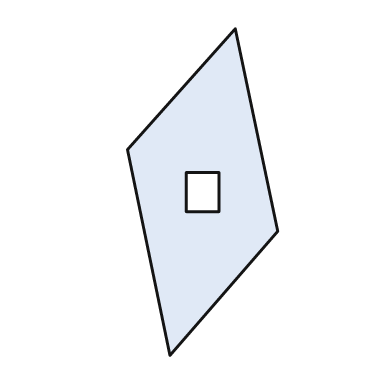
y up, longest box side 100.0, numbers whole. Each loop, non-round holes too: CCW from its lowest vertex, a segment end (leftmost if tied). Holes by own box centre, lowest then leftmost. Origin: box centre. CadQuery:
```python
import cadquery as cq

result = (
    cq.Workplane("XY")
    .moveTo(-10.0, -50.0)
    .lineTo(23.0, -12.0)
    .lineTo(10.0, 50.0)
    .lineTo(-23.0, 13.0)
    .close()
    .moveTo(-5.0, -6.0)
    .lineTo(5.0, -6.0)
    .lineTo(5.0, 6.0)
    .lineTo(-5.0, 6.0)
    .close()
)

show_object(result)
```